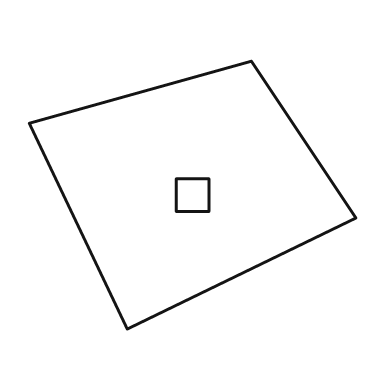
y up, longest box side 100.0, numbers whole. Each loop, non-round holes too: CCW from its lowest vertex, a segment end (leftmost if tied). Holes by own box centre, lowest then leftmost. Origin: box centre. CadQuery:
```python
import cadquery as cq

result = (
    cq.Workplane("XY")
    .moveTo(-20.0, -41.0)
    .lineTo(50.0, -7.0)
    .lineTo(18.0, 41.0)
    .lineTo(-50.0, 22.0)
    .close()
    .moveTo(-5.0, -5.0)
    .lineTo(5.0, -5.0)
    .lineTo(5.0, 5.0)
    .lineTo(-5.0, 5.0)
    .close()
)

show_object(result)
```